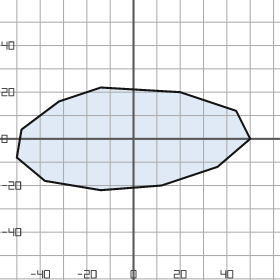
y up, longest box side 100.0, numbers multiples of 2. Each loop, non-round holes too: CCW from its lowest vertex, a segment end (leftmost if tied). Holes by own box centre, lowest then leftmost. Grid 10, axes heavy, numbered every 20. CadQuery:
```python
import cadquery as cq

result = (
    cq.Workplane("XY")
    .moveTo(-14.0, -22.0)
    .lineTo(12.0, -20.0)
    .lineTo(36.0, -12.0)
    .lineTo(50.0, 0.0)
    .lineTo(44.0, 12.0)
    .lineTo(20.0, 20.0)
    .lineTo(-14.0, 22.0)
    .lineTo(-32.0, 16.0)
    .lineTo(-48.0, 4.0)
    .lineTo(-50.0, -8.0)
    .lineTo(-38.0, -18.0)
    .close()
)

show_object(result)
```